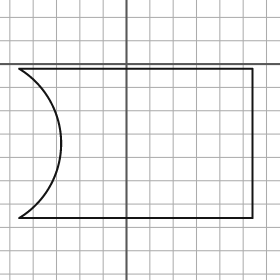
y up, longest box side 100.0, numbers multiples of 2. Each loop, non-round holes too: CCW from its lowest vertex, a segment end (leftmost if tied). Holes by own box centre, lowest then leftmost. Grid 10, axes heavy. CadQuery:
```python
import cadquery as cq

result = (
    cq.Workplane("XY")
    .moveTo(-46.0, -66.0)
    .lineTo(54.0, -66.0)
    .lineTo(54.0, -2.0)
    .lineTo(-46.0, -2.0)
    .threePointArc((-28.0, -34.0), (-46.0, -66.0))
    .close()
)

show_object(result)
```